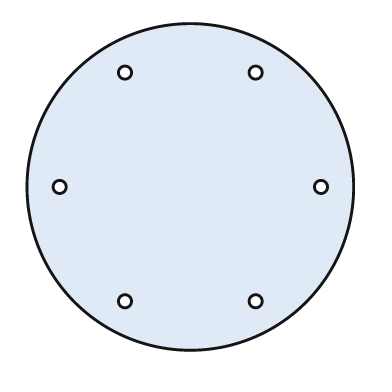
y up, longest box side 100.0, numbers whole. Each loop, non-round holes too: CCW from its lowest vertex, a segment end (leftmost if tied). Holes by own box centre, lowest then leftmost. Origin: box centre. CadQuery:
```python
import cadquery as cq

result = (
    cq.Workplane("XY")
    .moveTo(0.0, 0.0)
    .circle(50.0)
    .moveTo(-20.0, -35.0)
    .circle(2.0)
    .moveTo(20.0, -35.0)
    .circle(2.0)
    .moveTo(-40.0, 0.0)
    .circle(2.0)
    .moveTo(40.0, 0.0)
    .circle(2.0)
    .moveTo(-20.0, 35.0)
    .circle(2.0)
    .moveTo(20.0, 35.0)
    .circle(2.0)
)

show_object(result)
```